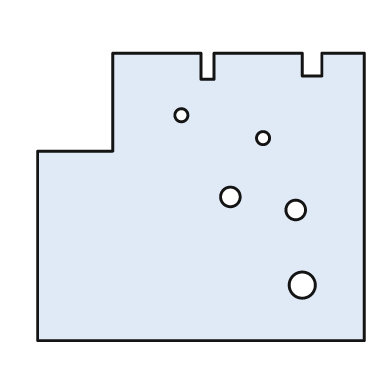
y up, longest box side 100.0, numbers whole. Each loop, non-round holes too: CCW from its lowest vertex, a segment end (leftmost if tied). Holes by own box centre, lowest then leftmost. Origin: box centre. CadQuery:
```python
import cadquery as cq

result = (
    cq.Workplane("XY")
    .moveTo(-50.0, -44.0)
    .lineTo(50.0, -44.0)
    .lineTo(50.0, 44.0)
    .lineTo(37.0, 44.0)
    .lineTo(37.0, 37.0)
    .lineTo(31.0, 37.0)
    .lineTo(31.0, 44.0)
    .lineTo(4.0, 44.0)
    .lineTo(4.0, 36.0)
    .lineTo(0.0, 36.0)
    .lineTo(0.0, 44.0)
    .lineTo(-27.0, 44.0)
    .lineTo(-27.0, 14.0)
    .lineTo(-50.0, 14.0)
    .close()
    .moveTo(31.0, -27.0)
    .circle(4.0)
    .moveTo(29.0, -4.0)
    .circle(3.0)
    .moveTo(9.0, 0.0)
    .circle(3.0)
    .moveTo(19.0, 18.0)
    .circle(2.0)
    .moveTo(-6.0, 25.0)
    .circle(2.0)
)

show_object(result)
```